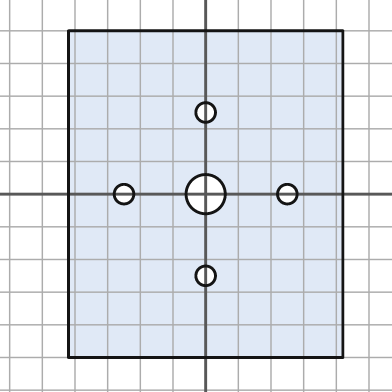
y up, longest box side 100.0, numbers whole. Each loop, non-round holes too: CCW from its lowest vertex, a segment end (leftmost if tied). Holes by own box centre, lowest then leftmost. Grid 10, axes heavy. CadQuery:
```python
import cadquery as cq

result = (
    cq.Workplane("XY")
    .moveTo(-42.0, -50.0)
    .lineTo(42.0, -50.0)
    .lineTo(42.0, 50.0)
    .lineTo(-42.0, 50.0)
    .close()
    .moveTo(0.0, -25.0)
    .circle(3.0)
    .moveTo(-25.0, 0.0)
    .circle(3.0)
    .moveTo(0.0, 0.0)
    .circle(6.0)
    .moveTo(25.0, 0.0)
    .circle(3.0)
    .moveTo(0.0, 25.0)
    .circle(3.0)
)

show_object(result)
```